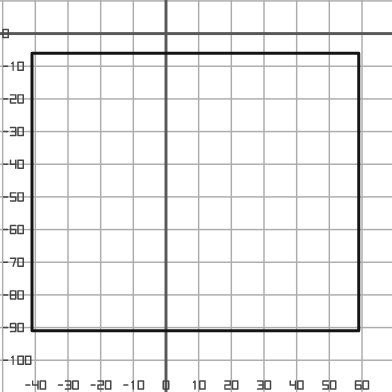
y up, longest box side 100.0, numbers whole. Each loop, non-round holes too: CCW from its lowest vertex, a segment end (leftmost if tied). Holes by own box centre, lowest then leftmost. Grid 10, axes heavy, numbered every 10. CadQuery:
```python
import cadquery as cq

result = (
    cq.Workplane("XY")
    .moveTo(-41.0, -91.0)
    .lineTo(59.0, -91.0)
    .lineTo(59.0, -6.0)
    .lineTo(-41.0, -6.0)
    .close()
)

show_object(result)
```